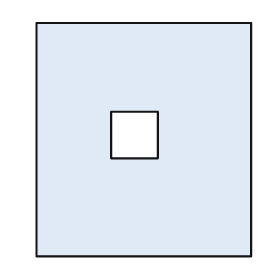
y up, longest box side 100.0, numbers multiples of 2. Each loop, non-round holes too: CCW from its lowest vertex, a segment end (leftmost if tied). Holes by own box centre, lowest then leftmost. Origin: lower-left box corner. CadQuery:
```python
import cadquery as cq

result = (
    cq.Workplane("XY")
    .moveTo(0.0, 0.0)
    .lineTo(92.0, 0.0)
    .lineTo(92.0, 100.0)
    .lineTo(0.0, 100.0)
    .close()
    .moveTo(32.0, 42.0)
    .lineTo(52.0, 42.0)
    .lineTo(52.0, 62.0)
    .lineTo(32.0, 62.0)
    .close()
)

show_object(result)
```